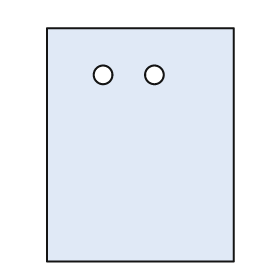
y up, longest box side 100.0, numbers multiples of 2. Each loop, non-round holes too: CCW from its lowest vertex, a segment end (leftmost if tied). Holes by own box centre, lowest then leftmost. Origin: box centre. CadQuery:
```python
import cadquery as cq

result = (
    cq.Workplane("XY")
    .moveTo(-40.0, -50.0)
    .lineTo(40.0, -50.0)
    .lineTo(40.0, 50.0)
    .lineTo(-40.0, 50.0)
    .close()
    .moveTo(-16.0, 30.0)
    .circle(4.0)
    .moveTo(6.0, 30.0)
    .circle(4.0)
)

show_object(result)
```